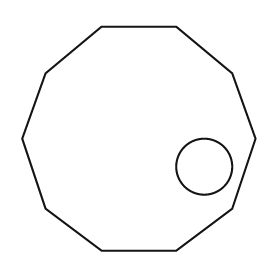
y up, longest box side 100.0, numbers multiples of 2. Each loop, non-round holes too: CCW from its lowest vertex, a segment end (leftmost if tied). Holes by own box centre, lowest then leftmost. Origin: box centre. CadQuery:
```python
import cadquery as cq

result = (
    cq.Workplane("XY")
    .moveTo(-16.0, -48.0)
    .lineTo(16.0, -48.0)
    .lineTo(40.0, -30.0)
    .lineTo(50.0, 0.0)
    .lineTo(40.0, 28.0)
    .lineTo(16.0, 48.0)
    .lineTo(-16.0, 48.0)
    .lineTo(-40.0, 28.0)
    .lineTo(-50.0, 0.0)
    .lineTo(-40.0, -30.0)
    .close()
    .moveTo(28.0, -12.0)
    .circle(12.0)
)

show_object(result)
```